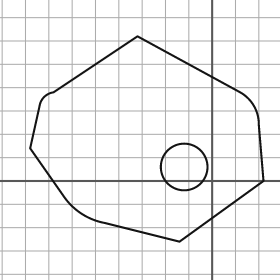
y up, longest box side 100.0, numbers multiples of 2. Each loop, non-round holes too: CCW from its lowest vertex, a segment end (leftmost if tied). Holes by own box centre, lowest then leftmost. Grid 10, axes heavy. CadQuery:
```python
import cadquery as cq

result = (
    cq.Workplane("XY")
    .moveTo(-14.0, -26.0)
    .lineTo(22.0, 0.0)
    .lineTo(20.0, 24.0)
    .threePointArc((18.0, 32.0), (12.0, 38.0))
    .lineTo(-32.0, 62.0)
    .lineTo(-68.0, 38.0)
    .threePointArc((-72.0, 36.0), (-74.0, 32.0))
    .lineTo(-78.0, 14.0)
    .lineTo(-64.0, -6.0)
    .threePointArc((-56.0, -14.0), (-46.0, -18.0))
    .close()
    .moveTo(-12.0, 6.0)
    .circle(10.0)
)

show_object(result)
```